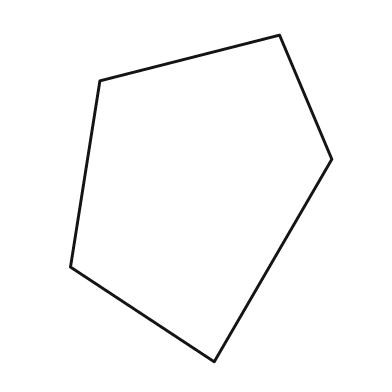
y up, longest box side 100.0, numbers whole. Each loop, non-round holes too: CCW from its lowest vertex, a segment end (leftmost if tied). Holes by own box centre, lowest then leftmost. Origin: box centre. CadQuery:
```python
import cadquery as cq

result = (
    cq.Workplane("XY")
    .moveTo(4.0, -50.0)
    .lineTo(40.0, 12.0)
    .lineTo(24.0, 50.0)
    .lineTo(-31.0, 36.0)
    .lineTo(-40.0, -21.0)
    .close()
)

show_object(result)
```